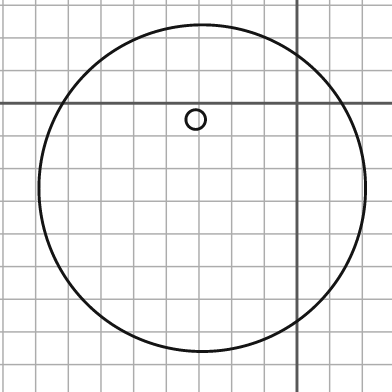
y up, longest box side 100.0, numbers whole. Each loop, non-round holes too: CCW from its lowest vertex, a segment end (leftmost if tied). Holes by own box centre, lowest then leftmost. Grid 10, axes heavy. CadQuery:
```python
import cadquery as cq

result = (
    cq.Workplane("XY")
    .moveTo(-29.0, -26.0)
    .circle(50.0)
    .moveTo(-31.0, -5.0)
    .circle(3.0)
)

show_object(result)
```